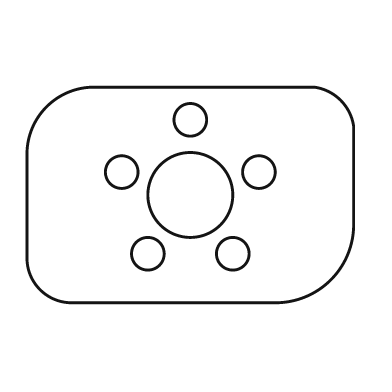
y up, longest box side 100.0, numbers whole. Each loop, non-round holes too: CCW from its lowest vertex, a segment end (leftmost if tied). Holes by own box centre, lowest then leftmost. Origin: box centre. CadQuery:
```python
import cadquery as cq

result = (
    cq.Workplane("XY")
    .moveTo(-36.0, -33.0)
    .lineTo(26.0, -33.0)
    .threePointArc((43.0, -26.0), (50.0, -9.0))
    .lineTo(50.0, 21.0)
    .threePointArc((46.0, 29.0), (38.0, 33.0))
    .lineTo(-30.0, 33.0)
    .threePointArc((-44.0, 27.0), (-50.0, 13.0))
    .lineTo(-50.0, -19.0)
    .threePointArc((-46.0, -29.0), (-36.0, -33.0))
    .close()
    .moveTo(-13.0, -18.0)
    .circle(5.0)
    .moveTo(13.0, -18.0)
    .circle(5.0)
    .moveTo(0.0, 0.0)
    .circle(13.0)
    .moveTo(-21.0, 7.0)
    .circle(5.0)
    .moveTo(21.0, 7.0)
    .circle(5.0)
    .moveTo(0.0, 23.0)
    .circle(5.0)
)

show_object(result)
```